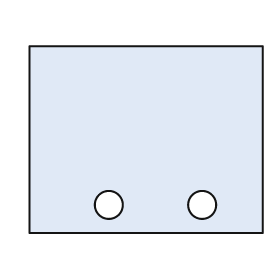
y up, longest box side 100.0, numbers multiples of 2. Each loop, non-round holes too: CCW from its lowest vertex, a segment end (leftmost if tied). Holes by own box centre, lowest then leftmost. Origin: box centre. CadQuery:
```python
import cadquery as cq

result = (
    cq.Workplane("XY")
    .moveTo(-50.0, -40.0)
    .lineTo(50.0, -40.0)
    .lineTo(50.0, 40.0)
    .lineTo(-50.0, 40.0)
    .close()
    .moveTo(-16.0, -28.0)
    .circle(6.0)
    .moveTo(24.0, -28.0)
    .circle(6.0)
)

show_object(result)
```